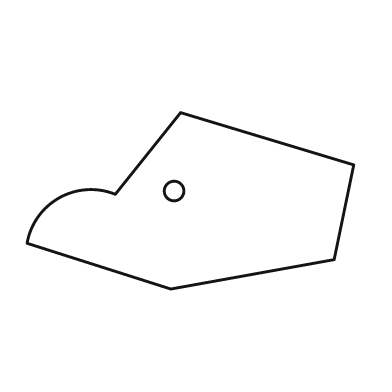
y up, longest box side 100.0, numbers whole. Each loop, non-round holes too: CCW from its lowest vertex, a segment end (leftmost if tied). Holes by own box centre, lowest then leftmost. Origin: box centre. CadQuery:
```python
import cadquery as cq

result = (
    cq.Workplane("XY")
    .moveTo(-6.0, -27.0)
    .lineTo(44.0, -18.0)
    .lineTo(50.0, 11.0)
    .lineTo(-3.0, 27.0)
    .lineTo(-23.0, 2.0)
    .threePointArc((-40.0, 1.0), (-50.0, -13.0))
    .close()
    .moveTo(-5.0, 3.0)
    .circle(3.0)
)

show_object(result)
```